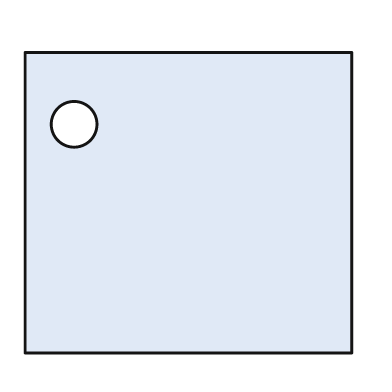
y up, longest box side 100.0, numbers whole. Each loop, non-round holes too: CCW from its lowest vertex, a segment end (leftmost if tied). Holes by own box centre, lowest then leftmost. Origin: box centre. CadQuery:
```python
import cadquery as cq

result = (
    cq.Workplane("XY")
    .moveTo(-50.0, -46.0)
    .lineTo(50.0, -46.0)
    .lineTo(50.0, 46.0)
    .lineTo(-50.0, 46.0)
    .close()
    .moveTo(-35.0, 24.0)
    .circle(7.0)
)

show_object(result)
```